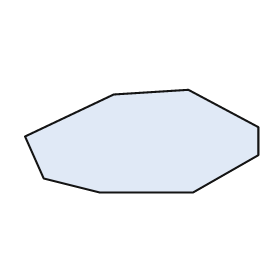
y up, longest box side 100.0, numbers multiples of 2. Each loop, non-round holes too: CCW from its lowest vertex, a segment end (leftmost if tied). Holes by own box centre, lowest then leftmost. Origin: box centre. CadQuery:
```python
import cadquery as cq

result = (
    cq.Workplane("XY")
    .moveTo(-18.0, -22.0)
    .lineTo(22.0, -22.0)
    .lineTo(50.0, -6.0)
    .lineTo(50.0, 6.0)
    .lineTo(20.0, 22.0)
    .lineTo(-12.0, 20.0)
    .lineTo(-50.0, 2.0)
    .lineTo(-42.0, -16.0)
    .close()
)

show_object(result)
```